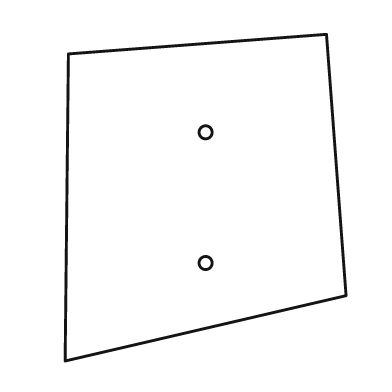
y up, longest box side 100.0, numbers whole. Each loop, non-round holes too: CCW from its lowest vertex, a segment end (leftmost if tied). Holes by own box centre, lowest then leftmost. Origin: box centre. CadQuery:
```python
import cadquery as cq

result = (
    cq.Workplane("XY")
    .moveTo(-43.0, -50.0)
    .lineTo(43.0, -30.0)
    .lineTo(37.0, 50.0)
    .lineTo(-42.0, 44.0)
    .close()
    .moveTo(0.0, -20.0)
    .circle(2.0)
    .moveTo(0.0, 20.0)
    .circle(2.0)
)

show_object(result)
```